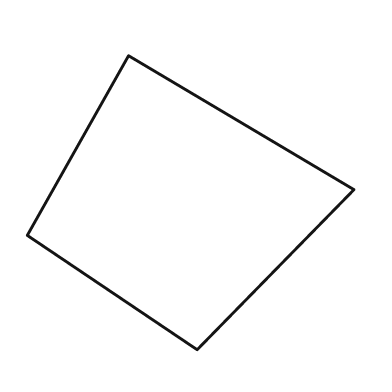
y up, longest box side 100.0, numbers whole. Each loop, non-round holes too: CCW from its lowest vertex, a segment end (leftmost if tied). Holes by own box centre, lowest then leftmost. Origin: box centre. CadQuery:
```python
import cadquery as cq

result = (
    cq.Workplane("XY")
    .moveTo(2.0, -45.0)
    .lineTo(50.0, 4.0)
    .lineTo(-19.0, 45.0)
    .lineTo(-50.0, -10.0)
    .close()
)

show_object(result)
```